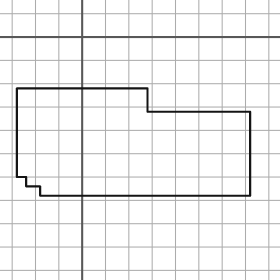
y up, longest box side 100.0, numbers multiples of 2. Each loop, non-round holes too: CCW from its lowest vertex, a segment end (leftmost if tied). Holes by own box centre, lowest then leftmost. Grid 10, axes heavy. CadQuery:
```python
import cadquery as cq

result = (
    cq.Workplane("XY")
    .moveTo(-18.0, -68.0)
    .lineTo(72.0, -68.0)
    .lineTo(72.0, -32.0)
    .lineTo(28.0, -32.0)
    .lineTo(28.0, -22.0)
    .lineTo(-28.0, -22.0)
    .lineTo(-28.0, -60.0)
    .lineTo(-24.0, -60.0)
    .lineTo(-24.0, -64.0)
    .lineTo(-18.0, -64.0)
    .close()
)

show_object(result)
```